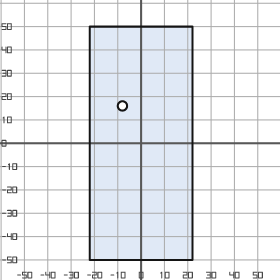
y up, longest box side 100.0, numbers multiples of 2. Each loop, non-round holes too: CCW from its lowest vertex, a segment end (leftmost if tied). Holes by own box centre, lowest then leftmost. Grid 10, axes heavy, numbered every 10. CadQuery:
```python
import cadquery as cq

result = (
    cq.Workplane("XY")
    .moveTo(-22.0, -50.0)
    .lineTo(22.0, -50.0)
    .lineTo(22.0, 50.0)
    .lineTo(-22.0, 50.0)
    .close()
    .moveTo(-8.0, 16.0)
    .circle(2.0)
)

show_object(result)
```